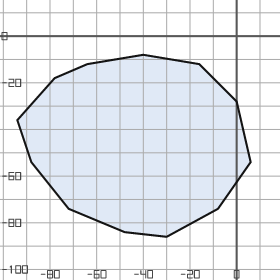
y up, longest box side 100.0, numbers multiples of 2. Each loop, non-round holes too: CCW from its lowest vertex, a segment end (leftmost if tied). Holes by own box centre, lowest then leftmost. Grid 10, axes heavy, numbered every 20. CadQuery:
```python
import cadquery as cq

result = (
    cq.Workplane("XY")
    .moveTo(-30.0, -86.0)
    .lineTo(-8.0, -74.0)
    .lineTo(6.0, -54.0)
    .lineTo(0.0, -28.0)
    .lineTo(-16.0, -12.0)
    .lineTo(-40.0, -8.0)
    .lineTo(-64.0, -12.0)
    .lineTo(-78.0, -18.0)
    .lineTo(-94.0, -36.0)
    .lineTo(-88.0, -54.0)
    .lineTo(-72.0, -74.0)
    .lineTo(-48.0, -84.0)
    .close()
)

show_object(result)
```